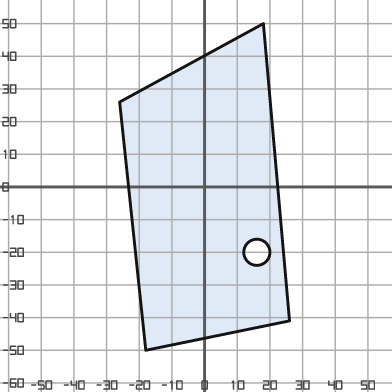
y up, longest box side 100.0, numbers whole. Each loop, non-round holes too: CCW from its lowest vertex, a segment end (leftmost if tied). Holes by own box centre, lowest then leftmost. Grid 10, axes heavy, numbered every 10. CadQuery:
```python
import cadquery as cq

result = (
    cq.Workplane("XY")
    .moveTo(-18.0, -50.0)
    .lineTo(26.0, -41.0)
    .lineTo(18.0, 50.0)
    .lineTo(-26.0, 26.0)
    .close()
    .moveTo(16.0, -20.0)
    .circle(4.0)
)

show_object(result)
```